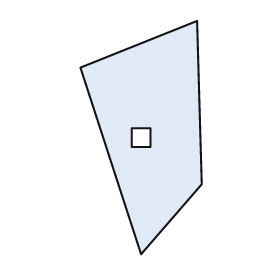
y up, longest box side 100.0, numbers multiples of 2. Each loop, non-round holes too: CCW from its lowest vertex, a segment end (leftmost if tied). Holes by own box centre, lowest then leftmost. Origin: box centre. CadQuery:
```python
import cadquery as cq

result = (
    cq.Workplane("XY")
    .moveTo(0.0, -50.0)
    .lineTo(26.0, -20.0)
    .lineTo(24.0, 50.0)
    .lineTo(-26.0, 30.0)
    .close()
    .moveTo(-4.0, -4.0)
    .lineTo(4.0, -4.0)
    .lineTo(4.0, 4.0)
    .lineTo(-4.0, 4.0)
    .close()
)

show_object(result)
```